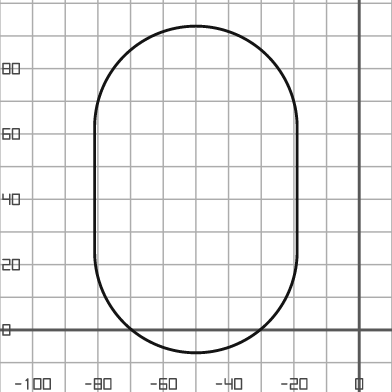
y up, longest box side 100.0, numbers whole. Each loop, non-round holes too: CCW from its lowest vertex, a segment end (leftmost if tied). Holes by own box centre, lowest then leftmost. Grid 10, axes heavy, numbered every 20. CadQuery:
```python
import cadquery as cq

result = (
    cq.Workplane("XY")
    .moveTo(-81.0, 24.0)
    .threePointArc((-50.0, -7.0), (-19.0, 24.0))
    .lineTo(-19.0, 62.0)
    .threePointArc((-50.0, 93.0), (-81.0, 62.0))
    .close()
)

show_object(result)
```